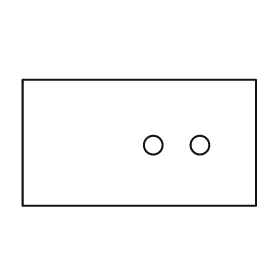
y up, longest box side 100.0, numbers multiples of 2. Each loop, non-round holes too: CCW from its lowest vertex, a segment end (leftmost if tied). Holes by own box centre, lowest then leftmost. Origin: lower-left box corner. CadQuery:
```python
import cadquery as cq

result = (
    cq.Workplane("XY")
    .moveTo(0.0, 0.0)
    .lineTo(100.0, 0.0)
    .lineTo(100.0, 54.0)
    .lineTo(0.0, 54.0)
    .close()
    .moveTo(56.0, 26.0)
    .circle(4.0)
    .moveTo(76.0, 26.0)
    .circle(4.0)
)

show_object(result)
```